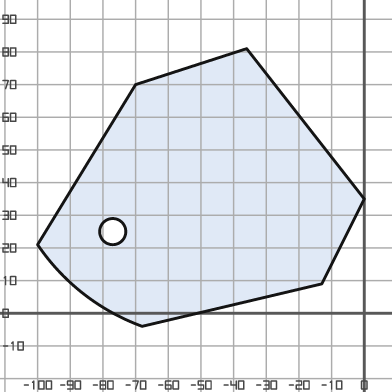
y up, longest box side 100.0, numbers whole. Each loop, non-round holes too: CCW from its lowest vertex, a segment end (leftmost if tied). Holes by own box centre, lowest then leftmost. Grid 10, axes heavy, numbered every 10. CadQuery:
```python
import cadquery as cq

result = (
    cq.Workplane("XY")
    .moveTo(-68.0, -4.0)
    .lineTo(-13.0, 9.0)
    .lineTo(0.0, 35.0)
    .lineTo(-36.0, 81.0)
    .lineTo(-70.0, 70.0)
    .lineTo(-100.0, 21.0)
    .threePointArc((-86.0, 6.0), (-68.0, -4.0))
    .close()
    .moveTo(-77.0, 25.0)
    .circle(4.0)
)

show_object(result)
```